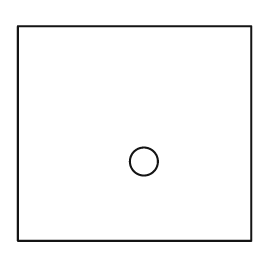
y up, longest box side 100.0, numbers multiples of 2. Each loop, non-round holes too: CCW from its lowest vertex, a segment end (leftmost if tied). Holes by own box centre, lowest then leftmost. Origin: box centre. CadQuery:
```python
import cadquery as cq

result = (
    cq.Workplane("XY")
    .moveTo(-50.0, -46.0)
    .lineTo(50.0, -46.0)
    .lineTo(50.0, 46.0)
    .lineTo(-50.0, 46.0)
    .close()
    .moveTo(4.0, -12.0)
    .circle(6.0)
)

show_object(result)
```